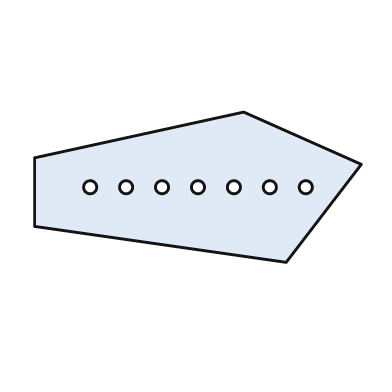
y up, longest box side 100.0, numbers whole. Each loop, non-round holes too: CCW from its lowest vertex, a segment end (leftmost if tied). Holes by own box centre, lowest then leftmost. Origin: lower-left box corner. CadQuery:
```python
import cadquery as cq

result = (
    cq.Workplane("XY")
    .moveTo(77.0, 0.0)
    .lineTo(100.0, 30.0)
    .lineTo(64.0, 46.0)
    .lineTo(0.0, 32.0)
    .lineTo(0.0, 11.0)
    .close()
    .moveTo(17.0, 23.0)
    .circle(2.0)
    .moveTo(28.0, 23.0)
    .circle(2.0)
    .moveTo(39.0, 23.0)
    .circle(2.0)
    .moveTo(50.0, 23.0)
    .circle(2.0)
    .moveTo(61.0, 23.0)
    .circle(2.0)
    .moveTo(72.0, 23.0)
    .circle(2.0)
    .moveTo(83.0, 23.0)
    .circle(2.0)
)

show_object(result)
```